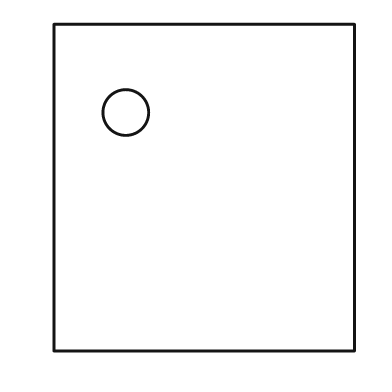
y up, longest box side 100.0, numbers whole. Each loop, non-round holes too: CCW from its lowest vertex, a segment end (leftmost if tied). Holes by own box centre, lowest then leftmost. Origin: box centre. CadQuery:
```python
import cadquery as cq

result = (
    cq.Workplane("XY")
    .moveTo(-46.0, -50.0)
    .lineTo(46.0, -50.0)
    .lineTo(46.0, 50.0)
    .lineTo(-46.0, 50.0)
    .close()
    .moveTo(-24.0, 23.0)
    .circle(7.0)
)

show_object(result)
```